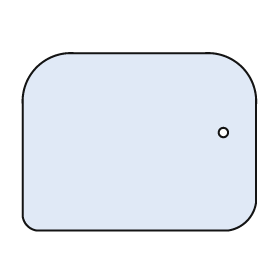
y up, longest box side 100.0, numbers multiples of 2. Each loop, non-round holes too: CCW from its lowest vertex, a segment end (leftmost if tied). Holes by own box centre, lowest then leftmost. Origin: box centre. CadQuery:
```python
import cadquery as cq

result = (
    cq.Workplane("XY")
    .moveTo(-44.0, -38.0)
    .lineTo(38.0, -38.0)
    .threePointArc((46.0, -34.0), (50.0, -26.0))
    .lineTo(50.0, 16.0)
    .threePointArc((44.0, 32.0), (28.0, 38.0))
    .lineTo(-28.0, 38.0)
    .threePointArc((-44.0, 32.0), (-50.0, 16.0))
    .lineTo(-50.0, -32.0)
    .threePointArc((-48.0, -36.0), (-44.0, -38.0))
    .close()
    .moveTo(36.0, 4.0)
    .circle(2.0)
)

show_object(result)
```